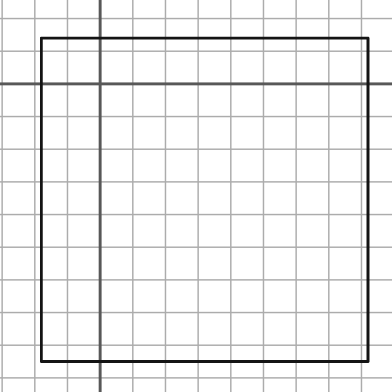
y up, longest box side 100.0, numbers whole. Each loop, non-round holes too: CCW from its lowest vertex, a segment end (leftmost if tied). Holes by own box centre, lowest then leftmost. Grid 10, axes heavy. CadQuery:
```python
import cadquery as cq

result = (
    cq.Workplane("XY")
    .moveTo(-18.0, -85.0)
    .lineTo(82.0, -85.0)
    .lineTo(82.0, 14.0)
    .lineTo(-18.0, 14.0)
    .close()
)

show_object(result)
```